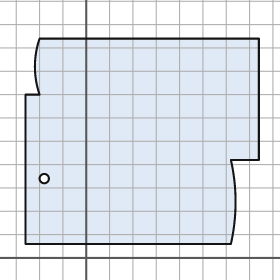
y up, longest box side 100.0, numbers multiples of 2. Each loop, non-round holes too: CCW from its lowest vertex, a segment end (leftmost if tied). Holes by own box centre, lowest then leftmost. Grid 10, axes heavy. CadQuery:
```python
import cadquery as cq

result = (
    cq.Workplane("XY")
    .moveTo(-26.0, 6.0)
    .lineTo(62.0, 6.0)
    .threePointArc((64.0, 24.0), (62.0, 42.0))
    .lineTo(74.0, 42.0)
    .lineTo(74.0, 94.0)
    .lineTo(-20.0, 94.0)
    .threePointArc((-22.0, 82.0), (-20.0, 70.0))
    .lineTo(-26.0, 70.0)
    .close()
    .moveTo(-18.0, 34.0)
    .circle(2.0)
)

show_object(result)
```